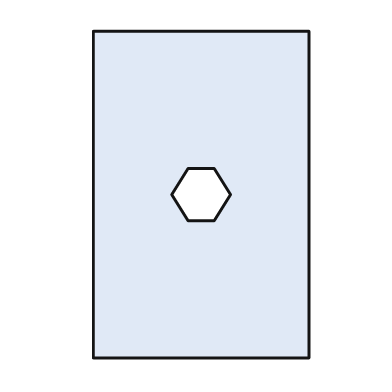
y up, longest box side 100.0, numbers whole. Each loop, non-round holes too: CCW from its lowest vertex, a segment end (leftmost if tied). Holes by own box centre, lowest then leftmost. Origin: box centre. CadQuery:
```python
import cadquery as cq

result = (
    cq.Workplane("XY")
    .moveTo(-33.0, -50.0)
    .lineTo(33.0, -50.0)
    .lineTo(33.0, 50.0)
    .lineTo(-33.0, 50.0)
    .close()
    .moveTo(-4.0, -8.0)
    .lineTo(4.0, -8.0)
    .lineTo(9.0, 0.0)
    .lineTo(4.0, 8.0)
    .lineTo(-4.0, 8.0)
    .lineTo(-9.0, 0.0)
    .close()
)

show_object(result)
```